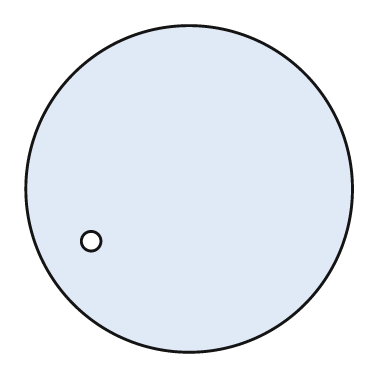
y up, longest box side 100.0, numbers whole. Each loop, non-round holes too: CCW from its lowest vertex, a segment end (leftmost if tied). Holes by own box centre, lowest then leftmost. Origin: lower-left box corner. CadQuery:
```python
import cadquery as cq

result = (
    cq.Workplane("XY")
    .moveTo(50.0, 50.0)
    .circle(50.0)
    .moveTo(20.0, 34.0)
    .circle(3.0)
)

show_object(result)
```